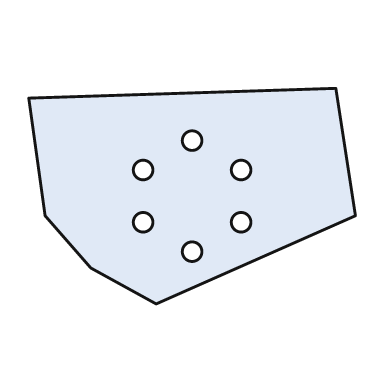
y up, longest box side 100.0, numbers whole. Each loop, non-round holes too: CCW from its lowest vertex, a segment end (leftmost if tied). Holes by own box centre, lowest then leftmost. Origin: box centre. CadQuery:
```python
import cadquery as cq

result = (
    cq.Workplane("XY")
    .moveTo(-11.0, -33.0)
    .lineTo(50.0, -6.0)
    .lineTo(44.0, 33.0)
    .lineTo(-50.0, 30.0)
    .lineTo(-45.0, -6.0)
    .lineTo(-31.0, -22.0)
    .close()
    .moveTo(0.0, -17.0)
    .circle(3.0)
    .moveTo(-15.0, -8.0)
    .circle(3.0)
    .moveTo(15.0, -8.0)
    .circle(3.0)
    .moveTo(-15.0, 8.0)
    .circle(3.0)
    .moveTo(15.0, 8.0)
    .circle(3.0)
    .moveTo(0.0, 17.0)
    .circle(3.0)
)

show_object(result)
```